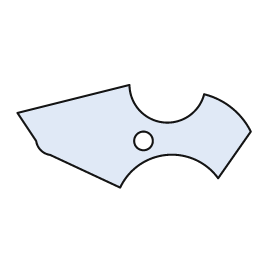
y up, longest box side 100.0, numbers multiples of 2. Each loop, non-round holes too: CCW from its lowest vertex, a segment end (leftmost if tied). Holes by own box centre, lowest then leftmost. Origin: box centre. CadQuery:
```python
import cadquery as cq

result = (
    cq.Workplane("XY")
    .moveTo(-6.0, -22.0)
    .threePointArc((14.0, -8.0), (36.0, -18.0))
    .lineTo(50.0, 2.0)
    .threePointArc((42.0, 12.0), (30.0, 18.0))
    .threePointArc((12.0, 6.0), (-2.0, 22.0))
    .lineTo(-50.0, 10.0)
    .lineTo(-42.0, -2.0)
    .threePointArc((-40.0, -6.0), (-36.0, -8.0))
    .close()
    .moveTo(4.0, -2.0)
    .circle(4.0)
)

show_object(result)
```